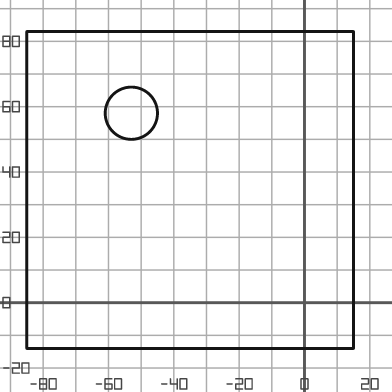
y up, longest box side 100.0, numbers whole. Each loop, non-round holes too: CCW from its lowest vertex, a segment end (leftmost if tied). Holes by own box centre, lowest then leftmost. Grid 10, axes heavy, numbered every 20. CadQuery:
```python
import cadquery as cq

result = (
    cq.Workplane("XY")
    .moveTo(-85.0, -14.0)
    .lineTo(15.0, -14.0)
    .lineTo(15.0, 83.0)
    .lineTo(-85.0, 83.0)
    .close()
    .moveTo(-53.0, 58.0)
    .circle(8.0)
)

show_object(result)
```